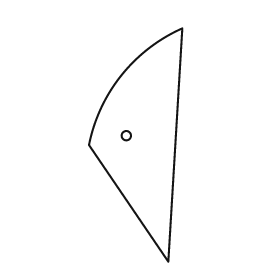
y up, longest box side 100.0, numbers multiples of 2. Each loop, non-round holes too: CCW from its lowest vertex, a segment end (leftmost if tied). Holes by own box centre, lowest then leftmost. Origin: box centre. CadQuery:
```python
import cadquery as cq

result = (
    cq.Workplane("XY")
    .moveTo(14.0, -50.0)
    .lineTo(20.0, 50.0)
    .threePointArc((-6.0, 30.0), (-20.0, 0.0))
    .close()
    .moveTo(-4.0, 4.0)
    .circle(2.0)
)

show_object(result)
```